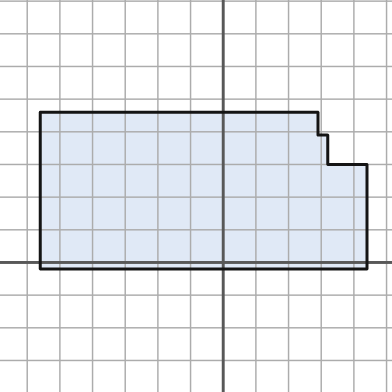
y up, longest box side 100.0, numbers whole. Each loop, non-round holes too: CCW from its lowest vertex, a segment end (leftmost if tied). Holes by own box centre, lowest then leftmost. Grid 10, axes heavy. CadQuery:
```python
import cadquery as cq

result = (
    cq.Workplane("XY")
    .moveTo(-56.0, -2.0)
    .lineTo(44.0, -2.0)
    .lineTo(44.0, 30.0)
    .lineTo(32.0, 30.0)
    .lineTo(32.0, 39.0)
    .lineTo(29.0, 39.0)
    .lineTo(29.0, 46.0)
    .lineTo(-56.0, 46.0)
    .close()
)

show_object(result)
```